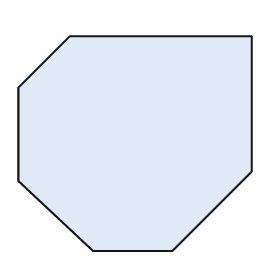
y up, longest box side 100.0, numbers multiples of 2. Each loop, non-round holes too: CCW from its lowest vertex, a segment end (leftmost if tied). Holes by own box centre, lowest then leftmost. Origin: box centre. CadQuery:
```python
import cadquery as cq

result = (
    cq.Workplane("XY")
    .moveTo(-18.0, -46.0)
    .lineTo(16.0, -46.0)
    .lineTo(50.0, -12.0)
    .lineTo(50.0, 46.0)
    .lineTo(-28.0, 46.0)
    .lineTo(-50.0, 24.0)
    .lineTo(-50.0, -16.0)
    .close()
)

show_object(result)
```